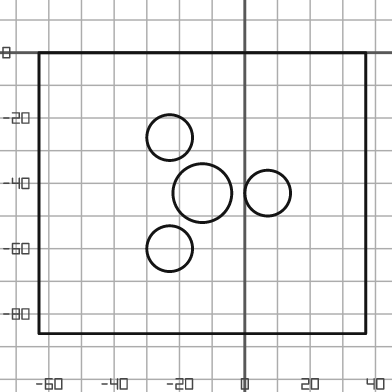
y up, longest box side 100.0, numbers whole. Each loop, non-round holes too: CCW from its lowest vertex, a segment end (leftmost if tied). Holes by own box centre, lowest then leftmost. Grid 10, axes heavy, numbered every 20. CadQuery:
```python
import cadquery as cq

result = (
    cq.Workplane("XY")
    .moveTo(-63.0, -86.0)
    .lineTo(37.0, -86.0)
    .lineTo(37.0, 0.0)
    .lineTo(-63.0, 0.0)
    .close()
    .moveTo(-23.0, -60.0)
    .circle(7.0)
    .moveTo(-13.0, -43.0)
    .circle(9.0)
    .moveTo(7.0, -43.0)
    .circle(7.0)
    .moveTo(-23.0, -26.0)
    .circle(7.0)
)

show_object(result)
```